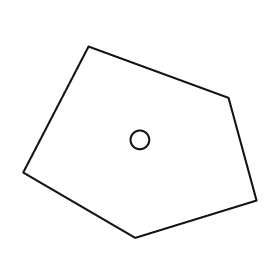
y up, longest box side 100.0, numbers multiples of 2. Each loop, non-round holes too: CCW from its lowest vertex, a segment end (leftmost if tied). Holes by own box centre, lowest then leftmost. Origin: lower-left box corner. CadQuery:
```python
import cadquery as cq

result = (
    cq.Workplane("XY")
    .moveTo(48.0, 0.0)
    .lineTo(100.0, 16.0)
    .lineTo(88.0, 60.0)
    .lineTo(28.0, 82.0)
    .lineTo(0.0, 28.0)
    .close()
    .moveTo(50.0, 42.0)
    .circle(4.0)
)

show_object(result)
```